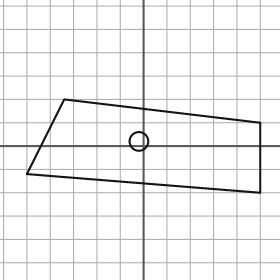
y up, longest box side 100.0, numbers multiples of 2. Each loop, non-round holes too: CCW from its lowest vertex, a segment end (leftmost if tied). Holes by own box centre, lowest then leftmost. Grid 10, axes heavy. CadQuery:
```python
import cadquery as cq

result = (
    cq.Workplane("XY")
    .moveTo(50.0, -20.0)
    .lineTo(50.0, 10.0)
    .lineTo(-34.0, 20.0)
    .lineTo(-50.0, -12.0)
    .close()
    .moveTo(-2.0, 2.0)
    .circle(4.0)
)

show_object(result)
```